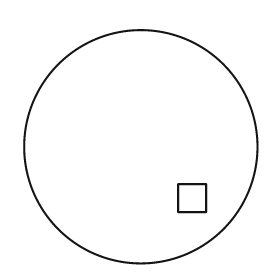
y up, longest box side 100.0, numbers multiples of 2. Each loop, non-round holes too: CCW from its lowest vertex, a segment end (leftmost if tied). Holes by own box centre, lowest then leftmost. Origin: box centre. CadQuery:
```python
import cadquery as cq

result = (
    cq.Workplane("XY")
    .moveTo(0.0, 0.0)
    .circle(50.0)
    .moveTo(16.0, -28.0)
    .lineTo(28.0, -28.0)
    .lineTo(28.0, -16.0)
    .lineTo(16.0, -16.0)
    .close()
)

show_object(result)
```